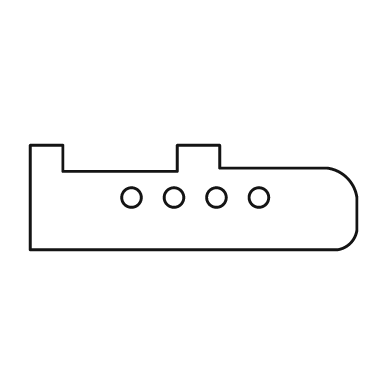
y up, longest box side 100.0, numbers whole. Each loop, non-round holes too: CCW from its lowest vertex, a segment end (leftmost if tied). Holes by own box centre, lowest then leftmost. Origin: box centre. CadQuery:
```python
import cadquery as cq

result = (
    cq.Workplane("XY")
    .moveTo(-50.0, -16.0)
    .lineTo(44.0, -16.0)
    .threePointArc((48.0, -14.0), (50.0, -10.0))
    .lineTo(50.0, 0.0)
    .threePointArc((47.0, 6.0), (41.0, 9.0))
    .lineTo(8.0, 9.0)
    .lineTo(8.0, 16.0)
    .lineTo(-5.0, 16.0)
    .lineTo(-5.0, 8.0)
    .lineTo(-40.0, 8.0)
    .lineTo(-40.0, 16.0)
    .lineTo(-50.0, 16.0)
    .close()
    .moveTo(-19.0, 0.0)
    .circle(3.0)
    .moveTo(-6.0, 0.0)
    .circle(3.0)
    .moveTo(7.0, 0.0)
    .circle(3.0)
    .moveTo(20.0, 0.0)
    .circle(3.0)
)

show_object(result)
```